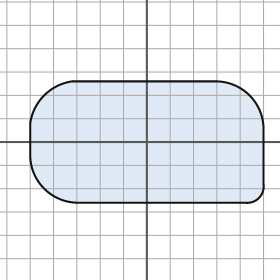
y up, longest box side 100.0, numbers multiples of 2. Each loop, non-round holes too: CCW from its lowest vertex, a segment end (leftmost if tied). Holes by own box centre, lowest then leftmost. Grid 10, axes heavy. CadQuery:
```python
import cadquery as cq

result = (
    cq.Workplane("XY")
    .moveTo(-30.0, -26.0)
    .lineTo(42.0, -26.0)
    .threePointArc((48.0, -24.0), (50.0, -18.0))
    .lineTo(50.0, 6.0)
    .threePointArc((44.0, 20.0), (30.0, 26.0))
    .lineTo(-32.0, 26.0)
    .threePointArc((-44.0, 20.0), (-50.0, 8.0))
    .lineTo(-50.0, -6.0)
    .threePointArc((-44.0, -20.0), (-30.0, -26.0))
    .close()
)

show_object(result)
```